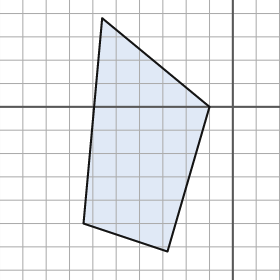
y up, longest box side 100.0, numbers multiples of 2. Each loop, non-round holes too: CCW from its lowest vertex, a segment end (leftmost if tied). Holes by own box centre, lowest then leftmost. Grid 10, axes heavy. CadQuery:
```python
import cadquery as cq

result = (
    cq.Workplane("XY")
    .moveTo(-28.0, -62.0)
    .lineTo(-10.0, 0.0)
    .lineTo(-56.0, 38.0)
    .lineTo(-64.0, -50.0)
    .close()
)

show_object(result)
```